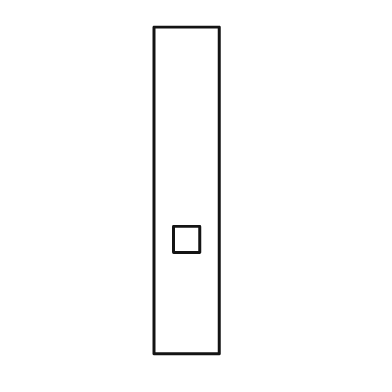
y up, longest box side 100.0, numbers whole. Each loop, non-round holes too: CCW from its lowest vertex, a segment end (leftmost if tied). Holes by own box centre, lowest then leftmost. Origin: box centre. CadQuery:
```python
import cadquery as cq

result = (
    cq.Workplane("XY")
    .moveTo(-10.0, -50.0)
    .lineTo(10.0, -50.0)
    .lineTo(10.0, 50.0)
    .lineTo(-10.0, 50.0)
    .close()
    .moveTo(-4.0, -19.0)
    .lineTo(4.0, -19.0)
    .lineTo(4.0, -11.0)
    .lineTo(-4.0, -11.0)
    .close()
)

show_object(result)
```